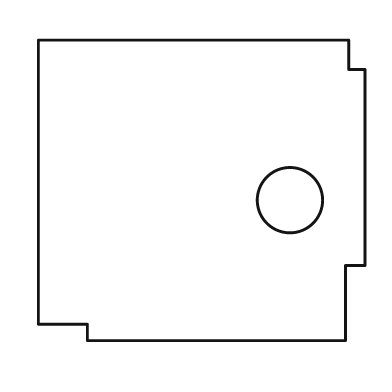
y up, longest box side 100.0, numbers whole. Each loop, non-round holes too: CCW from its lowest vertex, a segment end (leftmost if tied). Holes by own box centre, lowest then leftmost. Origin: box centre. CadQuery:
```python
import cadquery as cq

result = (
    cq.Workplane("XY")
    .moveTo(-35.0, -46.0)
    .lineTo(44.0, -46.0)
    .lineTo(44.0, -23.0)
    .lineTo(50.0, -23.0)
    .lineTo(50.0, 37.0)
    .lineTo(45.0, 37.0)
    .lineTo(45.0, 46.0)
    .lineTo(-50.0, 46.0)
    .lineTo(-50.0, -41.0)
    .lineTo(-35.0, -41.0)
    .close()
    .moveTo(27.0, -3.0)
    .circle(10.0)
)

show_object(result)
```